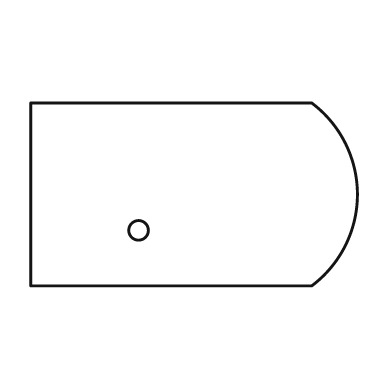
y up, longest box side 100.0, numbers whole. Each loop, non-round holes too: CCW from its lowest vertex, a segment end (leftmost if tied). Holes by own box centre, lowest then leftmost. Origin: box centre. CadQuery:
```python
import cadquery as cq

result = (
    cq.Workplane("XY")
    .moveTo(-50.0, -28.0)
    .lineTo(36.0, -28.0)
    .threePointArc((50.0, 0.0), (36.0, 28.0))
    .lineTo(-50.0, 28.0)
    .close()
    .moveTo(-17.0, -11.0)
    .circle(3.0)
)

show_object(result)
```